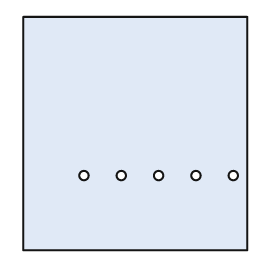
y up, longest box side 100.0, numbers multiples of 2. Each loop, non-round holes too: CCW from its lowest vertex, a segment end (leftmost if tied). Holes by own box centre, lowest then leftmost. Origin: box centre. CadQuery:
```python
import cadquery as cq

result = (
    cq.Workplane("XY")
    .moveTo(-48.0, -50.0)
    .lineTo(48.0, -50.0)
    .lineTo(48.0, 50.0)
    .lineTo(-48.0, 50.0)
    .close()
    .moveTo(-22.0, -18.0)
    .circle(2.0)
    .moveTo(-6.0, -18.0)
    .circle(2.0)
    .moveTo(10.0, -18.0)
    .circle(2.0)
    .moveTo(26.0, -18.0)
    .circle(2.0)
    .moveTo(42.0, -18.0)
    .circle(2.0)
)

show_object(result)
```